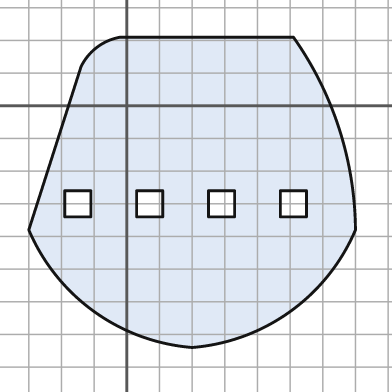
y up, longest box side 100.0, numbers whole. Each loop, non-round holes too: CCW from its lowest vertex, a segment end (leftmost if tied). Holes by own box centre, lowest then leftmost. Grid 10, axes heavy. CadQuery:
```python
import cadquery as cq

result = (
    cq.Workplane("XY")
    .moveTo(20.0, -74.0)
    .threePointArc((50.0, -63.0), (70.0, -38.0))
    .threePointArc((65.0, -7.0), (51.0, 21.0))
    .lineTo(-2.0, 21.0)
    .threePointArc((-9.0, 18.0), (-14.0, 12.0))
    .lineTo(-30.0, -38.0)
    .threePointArc((-10.0, -63.0), (20.0, -74.0))
    .close()
    .moveTo(-19.0, -34.0)
    .lineTo(-11.0, -34.0)
    .lineTo(-11.0, -26.0)
    .lineTo(-19.0, -26.0)
    .close()
    .moveTo(3.0, -34.0)
    .lineTo(11.0, -34.0)
    .lineTo(11.0, -26.0)
    .lineTo(3.0, -26.0)
    .close()
    .moveTo(25.0, -34.0)
    .lineTo(33.0, -34.0)
    .lineTo(33.0, -26.0)
    .lineTo(25.0, -26.0)
    .close()
    .moveTo(47.0, -34.0)
    .lineTo(55.0, -34.0)
    .lineTo(55.0, -26.0)
    .lineTo(47.0, -26.0)
    .close()
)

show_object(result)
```